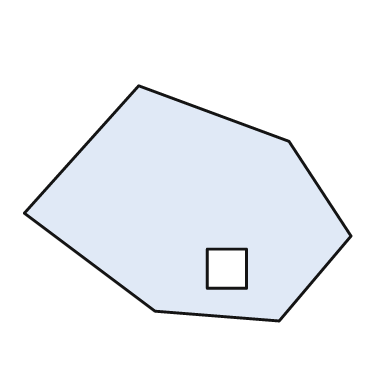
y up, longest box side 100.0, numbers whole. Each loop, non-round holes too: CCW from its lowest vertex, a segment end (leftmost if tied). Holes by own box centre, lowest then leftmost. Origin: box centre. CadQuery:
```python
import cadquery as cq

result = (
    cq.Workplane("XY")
    .moveTo(28.0, -36.0)
    .lineTo(50.0, -10.0)
    .lineTo(31.0, 19.0)
    .lineTo(-15.0, 36.0)
    .lineTo(-50.0, -3.0)
    .lineTo(-10.0, -33.0)
    .close()
    .moveTo(6.0, -26.0)
    .lineTo(18.0, -26.0)
    .lineTo(18.0, -14.0)
    .lineTo(6.0, -14.0)
    .close()
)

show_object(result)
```